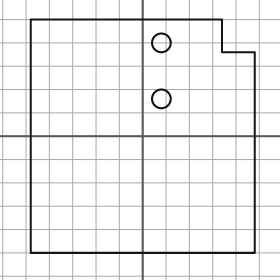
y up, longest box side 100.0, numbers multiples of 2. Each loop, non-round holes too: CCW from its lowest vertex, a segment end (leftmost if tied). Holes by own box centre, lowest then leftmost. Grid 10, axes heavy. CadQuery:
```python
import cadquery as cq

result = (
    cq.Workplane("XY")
    .moveTo(-48.0, -50.0)
    .lineTo(48.0, -50.0)
    .lineTo(48.0, 36.0)
    .lineTo(34.0, 36.0)
    .lineTo(34.0, 50.0)
    .lineTo(-48.0, 50.0)
    .close()
    .moveTo(8.0, 16.0)
    .circle(4.0)
    .moveTo(8.0, 40.0)
    .circle(4.0)
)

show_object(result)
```